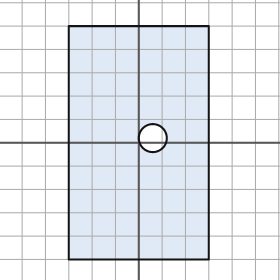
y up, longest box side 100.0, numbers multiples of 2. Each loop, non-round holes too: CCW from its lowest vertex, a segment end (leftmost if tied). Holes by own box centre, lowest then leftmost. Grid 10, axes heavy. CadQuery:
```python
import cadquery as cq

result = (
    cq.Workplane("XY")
    .moveTo(-30.0, -50.0)
    .lineTo(30.0, -50.0)
    .lineTo(30.0, 50.0)
    .lineTo(-30.0, 50.0)
    .close()
    .moveTo(6.0, 2.0)
    .circle(6.0)
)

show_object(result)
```